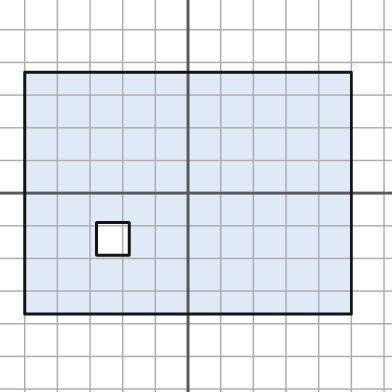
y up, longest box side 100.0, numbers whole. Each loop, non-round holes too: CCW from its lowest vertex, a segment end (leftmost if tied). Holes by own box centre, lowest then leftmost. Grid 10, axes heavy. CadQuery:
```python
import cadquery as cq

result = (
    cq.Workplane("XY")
    .moveTo(-50.0, -37.0)
    .lineTo(50.0, -37.0)
    .lineTo(50.0, 37.0)
    .lineTo(-50.0, 37.0)
    .close()
    .moveTo(-28.0, -19.0)
    .lineTo(-18.0, -19.0)
    .lineTo(-18.0, -9.0)
    .lineTo(-28.0, -9.0)
    .close()
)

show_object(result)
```